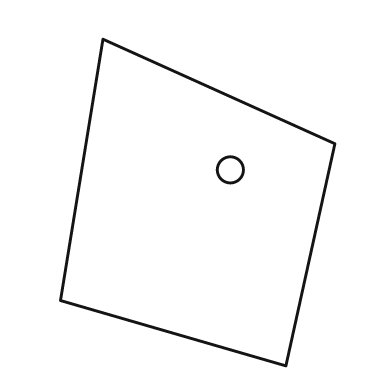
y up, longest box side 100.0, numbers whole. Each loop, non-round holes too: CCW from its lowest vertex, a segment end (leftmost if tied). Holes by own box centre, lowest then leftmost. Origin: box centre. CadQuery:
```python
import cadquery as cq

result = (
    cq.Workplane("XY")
    .moveTo(27.0, -50.0)
    .lineTo(42.0, 18.0)
    .lineTo(-29.0, 50.0)
    .lineTo(-42.0, -30.0)
    .close()
    .moveTo(10.0, 10.0)
    .circle(4.0)
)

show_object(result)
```